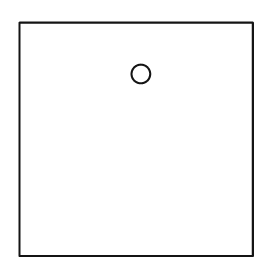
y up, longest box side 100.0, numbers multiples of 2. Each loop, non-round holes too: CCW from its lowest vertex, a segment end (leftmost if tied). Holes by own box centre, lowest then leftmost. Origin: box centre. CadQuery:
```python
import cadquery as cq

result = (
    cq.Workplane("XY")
    .moveTo(-50.0, -50.0)
    .lineTo(50.0, -50.0)
    .lineTo(50.0, 50.0)
    .lineTo(-50.0, 50.0)
    .close()
    .moveTo(2.0, 28.0)
    .circle(4.0)
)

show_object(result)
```